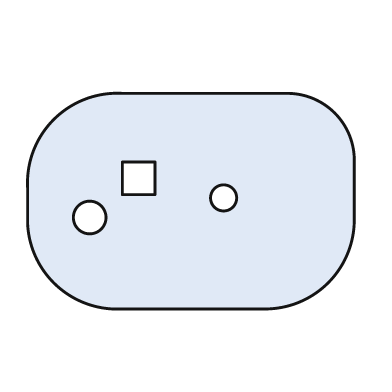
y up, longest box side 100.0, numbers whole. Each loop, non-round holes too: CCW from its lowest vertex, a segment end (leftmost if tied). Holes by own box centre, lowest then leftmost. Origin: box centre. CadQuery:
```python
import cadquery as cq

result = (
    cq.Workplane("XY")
    .moveTo(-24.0, -33.0)
    .lineTo(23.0, -33.0)
    .threePointArc((42.0, -25.0), (50.0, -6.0))
    .lineTo(50.0, 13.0)
    .threePointArc((44.0, 27.0), (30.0, 33.0))
    .lineTo(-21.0, 33.0)
    .threePointArc((-42.0, 25.0), (-50.0, 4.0))
    .lineTo(-50.0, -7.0)
    .threePointArc((-42.0, -25.0), (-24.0, -33.0))
    .close()
    .moveTo(-31.0, -5.0)
    .circle(5.0)
    .moveTo(10.0, 1.0)
    .circle(4.0)
    .moveTo(-21.0, 2.0)
    .lineTo(-11.0, 2.0)
    .lineTo(-11.0, 12.0)
    .lineTo(-21.0, 12.0)
    .close()
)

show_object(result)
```